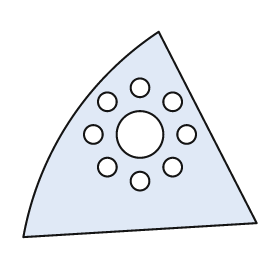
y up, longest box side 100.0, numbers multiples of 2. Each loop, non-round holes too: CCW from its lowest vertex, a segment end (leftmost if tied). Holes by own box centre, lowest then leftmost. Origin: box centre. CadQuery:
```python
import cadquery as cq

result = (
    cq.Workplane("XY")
    .moveTo(-50.0, -44.0)
    .lineTo(50.0, -38.0)
    .lineTo(8.0, 44.0)
    .threePointArc((-30.0, 6.0), (-50.0, -44.0))
    .close()
    .moveTo(0.0, -20.0)
    .circle(4.0)
    .moveTo(-14.0, -14.0)
    .circle(4.0)
    .moveTo(14.0, -14.0)
    .circle(4.0)
    .moveTo(-20.0, 0.0)
    .circle(4.0)
    .moveTo(0.0, 0.0)
    .circle(10.0)
    .moveTo(20.0, 0.0)
    .circle(4.0)
    .moveTo(-14.0, 14.0)
    .circle(4.0)
    .moveTo(14.0, 14.0)
    .circle(4.0)
    .moveTo(0.0, 20.0)
    .circle(4.0)
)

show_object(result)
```